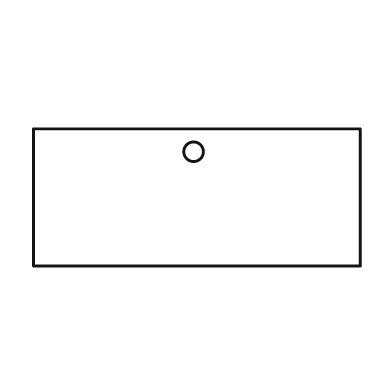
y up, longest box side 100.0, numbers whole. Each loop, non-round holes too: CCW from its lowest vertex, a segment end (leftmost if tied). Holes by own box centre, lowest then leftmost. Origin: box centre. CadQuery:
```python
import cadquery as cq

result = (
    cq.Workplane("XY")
    .moveTo(-50.0, -21.0)
    .lineTo(50.0, -21.0)
    .lineTo(50.0, 21.0)
    .lineTo(-50.0, 21.0)
    .close()
    .moveTo(-1.0, 14.0)
    .circle(3.0)
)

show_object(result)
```